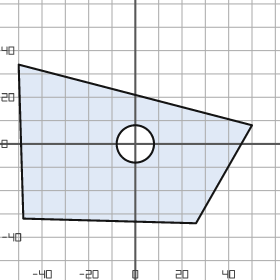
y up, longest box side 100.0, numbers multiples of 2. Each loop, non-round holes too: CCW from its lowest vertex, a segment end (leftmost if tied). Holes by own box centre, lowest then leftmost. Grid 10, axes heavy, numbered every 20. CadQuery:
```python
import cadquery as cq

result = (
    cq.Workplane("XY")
    .moveTo(26.0, -34.0)
    .lineTo(50.0, 8.0)
    .lineTo(-50.0, 34.0)
    .lineTo(-48.0, -32.0)
    .close()
    .moveTo(0.0, 0.0)
    .circle(8.0)
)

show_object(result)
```